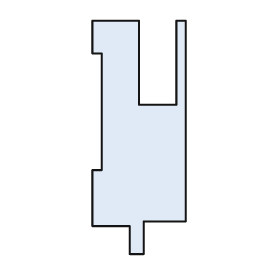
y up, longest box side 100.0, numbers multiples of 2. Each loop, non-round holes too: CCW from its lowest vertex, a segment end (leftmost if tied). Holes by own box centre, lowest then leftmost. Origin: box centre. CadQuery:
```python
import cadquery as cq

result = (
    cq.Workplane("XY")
    .moveTo(-4.0, -50.0)
    .lineTo(2.0, -50.0)
    .lineTo(2.0, -36.0)
    .lineTo(20.0, -36.0)
    .lineTo(20.0, 50.0)
    .lineTo(16.0, 50.0)
    .lineTo(16.0, 14.0)
    .lineTo(0.0, 14.0)
    .lineTo(0.0, 50.0)
    .lineTo(-20.0, 50.0)
    .lineTo(-20.0, 36.0)
    .lineTo(-16.0, 36.0)
    .lineTo(-16.0, -14.0)
    .lineTo(-20.0, -14.0)
    .lineTo(-20.0, -38.0)
    .lineTo(-4.0, -38.0)
    .close()
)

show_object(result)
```